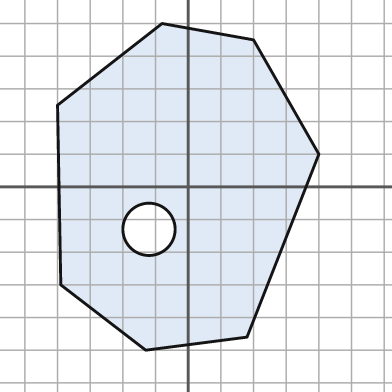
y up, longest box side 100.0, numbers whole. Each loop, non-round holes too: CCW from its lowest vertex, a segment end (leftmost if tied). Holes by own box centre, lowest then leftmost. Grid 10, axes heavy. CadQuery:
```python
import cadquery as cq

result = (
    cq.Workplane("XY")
    .moveTo(-13.0, -50.0)
    .lineTo(18.0, -46.0)
    .lineTo(40.0, 10.0)
    .lineTo(20.0, 45.0)
    .lineTo(-8.0, 50.0)
    .lineTo(-40.0, 25.0)
    .lineTo(-39.0, -30.0)
    .close()
    .moveTo(-12.0, -13.0)
    .circle(8.0)
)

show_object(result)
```